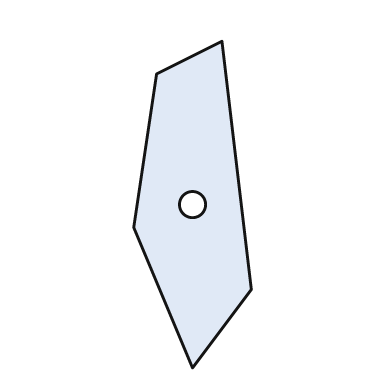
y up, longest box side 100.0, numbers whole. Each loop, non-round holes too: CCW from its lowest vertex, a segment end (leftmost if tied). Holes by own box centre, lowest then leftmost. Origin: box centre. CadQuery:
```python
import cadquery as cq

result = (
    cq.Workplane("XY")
    .moveTo(0.0, -50.0)
    .lineTo(18.0, -26.0)
    .lineTo(9.0, 50.0)
    .lineTo(-11.0, 40.0)
    .lineTo(-18.0, -7.0)
    .close()
    .moveTo(0.0, 0.0)
    .circle(4.0)
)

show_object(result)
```